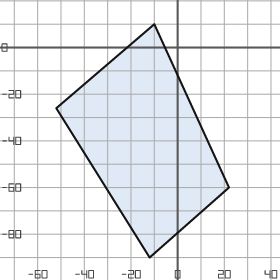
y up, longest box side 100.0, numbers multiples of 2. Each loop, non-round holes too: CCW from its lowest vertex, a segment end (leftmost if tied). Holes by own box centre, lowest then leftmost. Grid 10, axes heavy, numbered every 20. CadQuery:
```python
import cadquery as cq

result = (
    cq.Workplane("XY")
    .moveTo(-12.0, -90.0)
    .lineTo(22.0, -60.0)
    .lineTo(-10.0, 10.0)
    .lineTo(-52.0, -26.0)
    .close()
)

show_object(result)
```